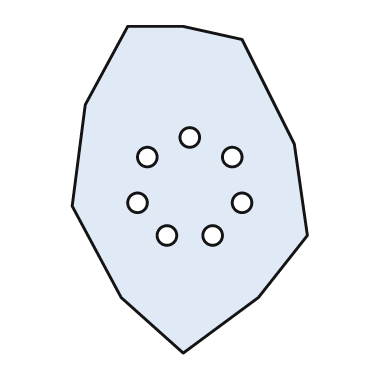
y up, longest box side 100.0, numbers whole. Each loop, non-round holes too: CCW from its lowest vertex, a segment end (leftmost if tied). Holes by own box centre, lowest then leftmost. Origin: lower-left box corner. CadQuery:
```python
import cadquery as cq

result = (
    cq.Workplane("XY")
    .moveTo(34.0, 0.0)
    .lineTo(57.0, 17.0)
    .lineTo(72.0, 36.0)
    .lineTo(68.0, 64.0)
    .lineTo(52.0, 96.0)
    .lineTo(34.0, 100.0)
    .lineTo(17.0, 100.0)
    .lineTo(4.0, 76.0)
    .lineTo(0.0, 45.0)
    .lineTo(15.0, 17.0)
    .close()
    .moveTo(29.0, 36.0)
    .circle(3.0)
    .moveTo(43.0, 36.0)
    .circle(3.0)
    .moveTo(20.0, 46.0)
    .circle(3.0)
    .moveTo(52.0, 46.0)
    .circle(3.0)
    .moveTo(23.0, 60.0)
    .circle(3.0)
    .moveTo(49.0, 60.0)
    .circle(3.0)
    .moveTo(36.0, 66.0)
    .circle(3.0)
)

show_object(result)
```